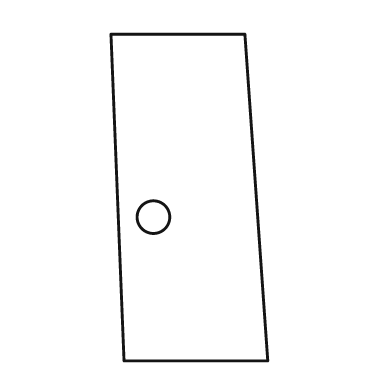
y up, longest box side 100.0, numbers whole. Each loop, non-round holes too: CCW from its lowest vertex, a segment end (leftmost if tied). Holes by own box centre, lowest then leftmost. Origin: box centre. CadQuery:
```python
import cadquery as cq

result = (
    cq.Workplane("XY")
    .moveTo(-20.0, -50.0)
    .lineTo(24.0, -50.0)
    .lineTo(17.0, 50.0)
    .lineTo(-24.0, 50.0)
    .close()
    .moveTo(-11.0, -6.0)
    .circle(5.0)
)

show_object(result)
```